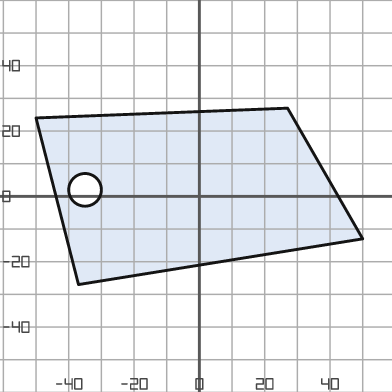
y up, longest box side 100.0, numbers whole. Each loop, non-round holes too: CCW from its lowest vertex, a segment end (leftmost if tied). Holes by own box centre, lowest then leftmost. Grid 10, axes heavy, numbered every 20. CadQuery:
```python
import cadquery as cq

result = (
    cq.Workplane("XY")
    .moveTo(-37.0, -27.0)
    .lineTo(50.0, -13.0)
    .lineTo(27.0, 27.0)
    .lineTo(-50.0, 24.0)
    .close()
    .moveTo(-35.0, 2.0)
    .circle(5.0)
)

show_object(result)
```